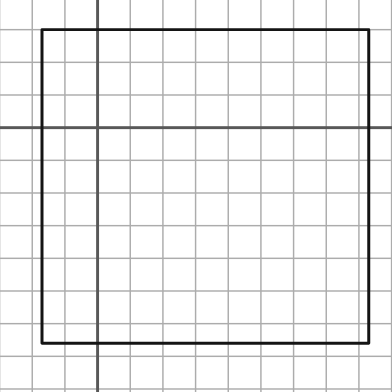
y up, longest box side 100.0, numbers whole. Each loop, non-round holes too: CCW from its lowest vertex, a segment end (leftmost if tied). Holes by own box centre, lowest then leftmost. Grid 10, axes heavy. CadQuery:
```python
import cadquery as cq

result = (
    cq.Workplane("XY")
    .moveTo(-17.0, -66.0)
    .lineTo(83.0, -66.0)
    .lineTo(83.0, 30.0)
    .lineTo(-17.0, 30.0)
    .close()
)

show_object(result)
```